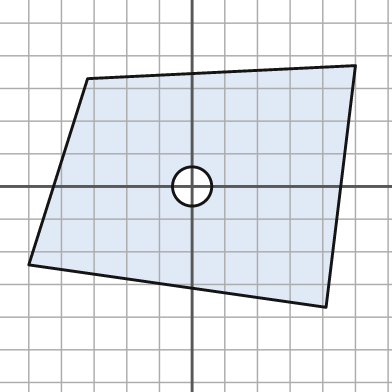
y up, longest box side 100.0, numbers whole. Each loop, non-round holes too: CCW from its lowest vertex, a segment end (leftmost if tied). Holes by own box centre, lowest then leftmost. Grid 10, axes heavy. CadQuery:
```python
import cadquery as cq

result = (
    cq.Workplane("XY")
    .moveTo(41.0, -37.0)
    .lineTo(50.0, 37.0)
    .lineTo(-32.0, 33.0)
    .lineTo(-50.0, -24.0)
    .close()
    .moveTo(0.0, 0.0)
    .circle(6.0)
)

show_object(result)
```